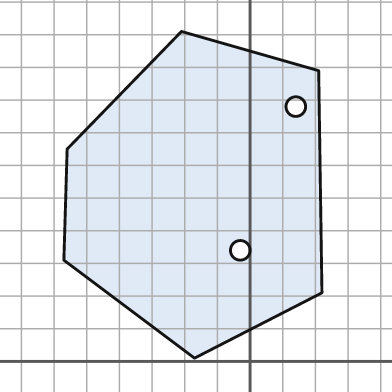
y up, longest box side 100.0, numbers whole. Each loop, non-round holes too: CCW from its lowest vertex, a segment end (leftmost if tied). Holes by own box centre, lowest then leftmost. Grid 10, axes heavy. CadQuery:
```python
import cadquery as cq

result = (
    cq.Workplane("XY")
    .moveTo(-17.0, 1.0)
    .lineTo(22.0, 21.0)
    .lineTo(21.0, 89.0)
    .lineTo(-21.0, 101.0)
    .lineTo(-56.0, 65.0)
    .lineTo(-57.0, 31.0)
    .close()
    .moveTo(-3.0, 34.0)
    .circle(3.0)
    .moveTo(14.0, 78.0)
    .circle(3.0)
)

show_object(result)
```